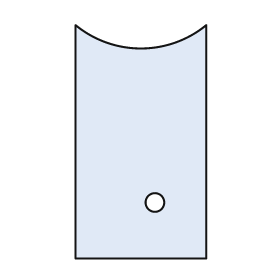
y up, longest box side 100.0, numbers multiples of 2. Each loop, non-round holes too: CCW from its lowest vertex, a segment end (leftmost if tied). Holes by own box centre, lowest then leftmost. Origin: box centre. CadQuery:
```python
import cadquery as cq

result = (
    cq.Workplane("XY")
    .moveTo(-28.0, -50.0)
    .lineTo(28.0, -50.0)
    .lineTo(28.0, 50.0)
    .threePointArc((0.0, 40.0), (-28.0, 50.0))
    .close()
    .moveTo(6.0, -26.0)
    .circle(4.0)
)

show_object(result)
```